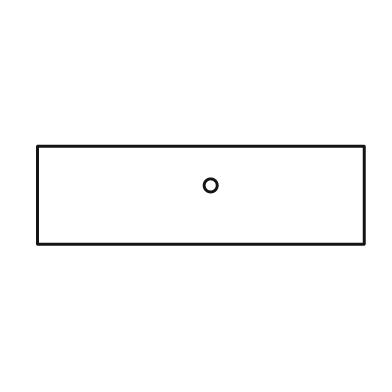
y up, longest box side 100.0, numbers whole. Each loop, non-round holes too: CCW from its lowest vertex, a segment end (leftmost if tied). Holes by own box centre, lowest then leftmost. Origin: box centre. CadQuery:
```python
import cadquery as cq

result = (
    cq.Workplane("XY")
    .moveTo(-50.0, -15.0)
    .lineTo(50.0, -15.0)
    .lineTo(50.0, 15.0)
    .lineTo(-50.0, 15.0)
    .close()
    .moveTo(3.0, 3.0)
    .circle(2.0)
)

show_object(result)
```